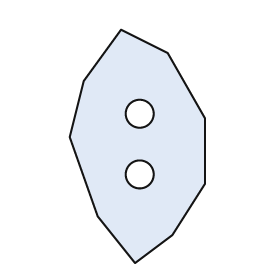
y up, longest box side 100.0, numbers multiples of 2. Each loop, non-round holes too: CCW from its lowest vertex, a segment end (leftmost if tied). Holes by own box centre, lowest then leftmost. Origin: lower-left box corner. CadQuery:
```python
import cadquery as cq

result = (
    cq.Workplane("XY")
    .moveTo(28.0, 0.0)
    .lineTo(44.0, 12.0)
    .lineTo(58.0, 34.0)
    .lineTo(58.0, 62.0)
    .lineTo(42.0, 90.0)
    .lineTo(22.0, 100.0)
    .lineTo(6.0, 78.0)
    .lineTo(0.0, 54.0)
    .lineTo(12.0, 20.0)
    .close()
    .moveTo(30.0, 38.0)
    .circle(6.0)
    .moveTo(30.0, 64.0)
    .circle(6.0)
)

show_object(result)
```